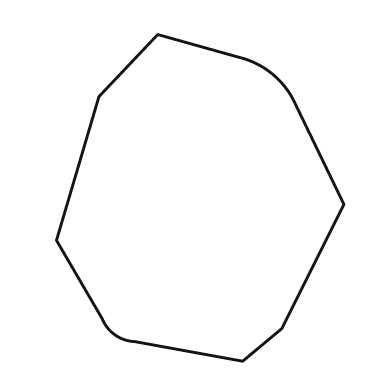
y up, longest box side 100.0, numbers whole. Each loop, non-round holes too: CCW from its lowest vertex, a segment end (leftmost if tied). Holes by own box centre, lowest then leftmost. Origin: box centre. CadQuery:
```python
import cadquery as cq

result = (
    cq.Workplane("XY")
    .moveTo(13.0, -50.0)
    .lineTo(25.0, -40.0)
    .lineTo(44.0, -2.0)
    .lineTo(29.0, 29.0)
    .threePointArc((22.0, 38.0), (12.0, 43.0))
    .lineTo(-13.0, 50.0)
    .lineTo(-31.0, 31.0)
    .lineTo(-44.0, -13.0)
    .lineTo(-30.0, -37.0)
    .threePointArc((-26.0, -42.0), (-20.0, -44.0))
    .close()
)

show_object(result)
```